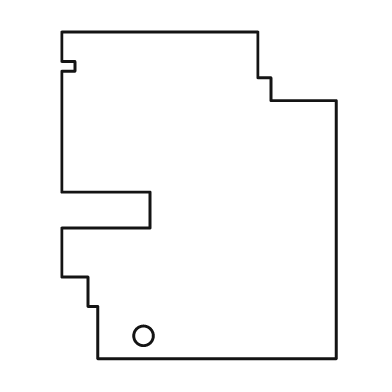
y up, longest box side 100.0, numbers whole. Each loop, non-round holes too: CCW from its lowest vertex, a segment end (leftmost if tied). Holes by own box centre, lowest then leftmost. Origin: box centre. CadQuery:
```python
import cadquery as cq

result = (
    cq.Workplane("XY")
    .moveTo(-31.0, -50.0)
    .lineTo(42.0, -50.0)
    .lineTo(42.0, 29.0)
    .lineTo(22.0, 29.0)
    .lineTo(22.0, 36.0)
    .lineTo(18.0, 36.0)
    .lineTo(18.0, 50.0)
    .lineTo(-42.0, 50.0)
    .lineTo(-42.0, 41.0)
    .lineTo(-38.0, 41.0)
    .lineTo(-38.0, 38.0)
    .lineTo(-42.0, 38.0)
    .lineTo(-42.0, 1.0)
    .lineTo(-15.0, 1.0)
    .lineTo(-15.0, -10.0)
    .lineTo(-42.0, -10.0)
    .lineTo(-42.0, -25.0)
    .lineTo(-34.0, -25.0)
    .lineTo(-34.0, -34.0)
    .lineTo(-31.0, -34.0)
    .close()
    .moveTo(-17.0, -43.0)
    .circle(3.0)
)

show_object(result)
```